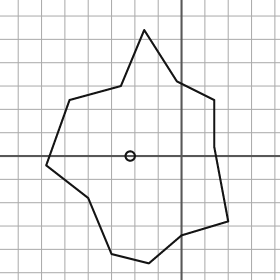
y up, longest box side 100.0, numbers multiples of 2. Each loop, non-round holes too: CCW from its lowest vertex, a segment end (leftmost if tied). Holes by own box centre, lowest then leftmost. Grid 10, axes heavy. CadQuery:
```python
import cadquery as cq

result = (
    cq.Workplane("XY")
    .moveTo(-14.0, -46.0)
    .lineTo(0.0, -34.0)
    .lineTo(20.0, -28.0)
    .lineTo(14.0, 4.0)
    .lineTo(14.0, 24.0)
    .lineTo(-2.0, 32.0)
    .lineTo(-16.0, 54.0)
    .lineTo(-26.0, 30.0)
    .lineTo(-48.0, 24.0)
    .lineTo(-58.0, -4.0)
    .lineTo(-40.0, -18.0)
    .lineTo(-30.0, -42.0)
    .close()
    .moveTo(-22.0, 0.0)
    .circle(2.0)
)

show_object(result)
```